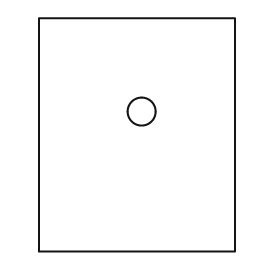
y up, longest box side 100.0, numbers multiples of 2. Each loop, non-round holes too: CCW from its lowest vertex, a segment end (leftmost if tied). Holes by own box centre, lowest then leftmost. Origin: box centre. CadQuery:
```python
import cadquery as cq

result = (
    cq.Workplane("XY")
    .moveTo(-42.0, -50.0)
    .lineTo(42.0, -50.0)
    .lineTo(42.0, 50.0)
    .lineTo(-42.0, 50.0)
    .close()
    .moveTo(2.0, 10.0)
    .circle(6.0)
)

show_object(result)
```